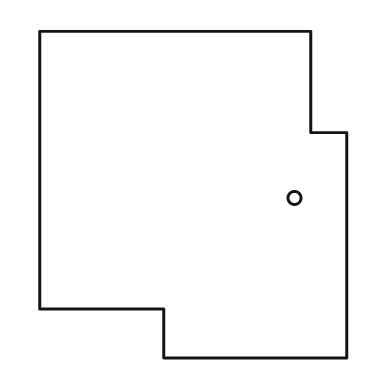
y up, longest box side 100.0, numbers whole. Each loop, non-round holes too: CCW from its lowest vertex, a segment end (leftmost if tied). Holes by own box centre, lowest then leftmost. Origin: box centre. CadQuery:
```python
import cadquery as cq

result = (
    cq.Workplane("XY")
    .moveTo(-9.0, -50.0)
    .lineTo(47.0, -50.0)
    .lineTo(47.0, 19.0)
    .lineTo(36.0, 19.0)
    .lineTo(36.0, 50.0)
    .lineTo(-47.0, 50.0)
    .lineTo(-47.0, -35.0)
    .lineTo(-9.0, -35.0)
    .close()
    .moveTo(31.0, -1.0)
    .circle(2.0)
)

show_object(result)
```